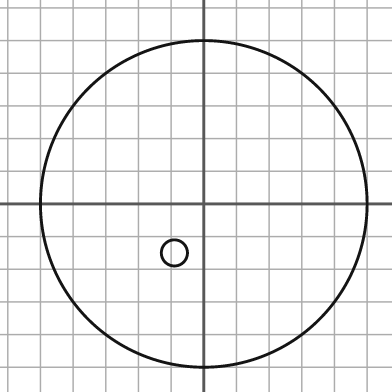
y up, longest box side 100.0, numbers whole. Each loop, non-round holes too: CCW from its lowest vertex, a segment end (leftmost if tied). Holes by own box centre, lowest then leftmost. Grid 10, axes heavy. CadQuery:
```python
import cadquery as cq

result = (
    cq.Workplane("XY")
    .moveTo(0.0, 0.0)
    .circle(50.0)
    .moveTo(-9.0, -15.0)
    .circle(4.0)
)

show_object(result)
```